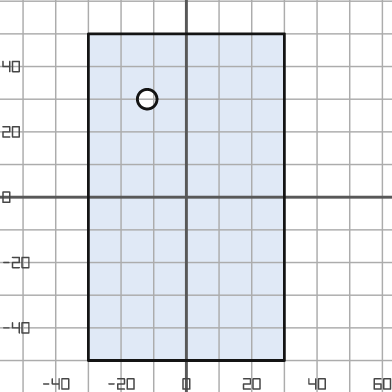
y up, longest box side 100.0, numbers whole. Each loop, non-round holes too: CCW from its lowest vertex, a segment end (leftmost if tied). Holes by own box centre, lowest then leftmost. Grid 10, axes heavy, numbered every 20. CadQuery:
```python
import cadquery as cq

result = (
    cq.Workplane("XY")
    .moveTo(-30.0, -50.0)
    .lineTo(30.0, -50.0)
    .lineTo(30.0, 50.0)
    .lineTo(-30.0, 50.0)
    .close()
    .moveTo(-12.0, 30.0)
    .circle(3.0)
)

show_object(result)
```